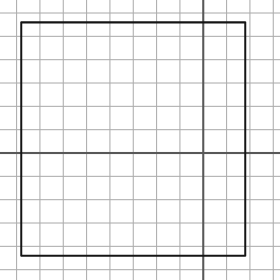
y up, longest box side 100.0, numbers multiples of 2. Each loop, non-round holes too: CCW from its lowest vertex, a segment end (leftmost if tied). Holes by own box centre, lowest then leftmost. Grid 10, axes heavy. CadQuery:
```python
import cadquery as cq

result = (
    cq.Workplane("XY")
    .moveTo(-78.0, -44.0)
    .lineTo(18.0, -44.0)
    .lineTo(18.0, 56.0)
    .lineTo(-78.0, 56.0)
    .close()
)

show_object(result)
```